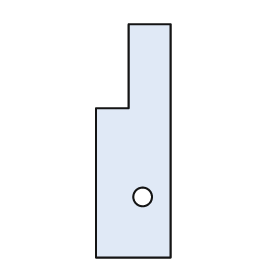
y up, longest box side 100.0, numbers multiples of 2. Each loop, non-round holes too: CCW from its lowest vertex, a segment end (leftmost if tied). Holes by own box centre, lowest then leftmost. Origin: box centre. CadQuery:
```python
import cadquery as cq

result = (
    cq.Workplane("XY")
    .moveTo(-16.0, -50.0)
    .lineTo(16.0, -50.0)
    .lineTo(16.0, 50.0)
    .lineTo(-2.0, 50.0)
    .lineTo(-2.0, 14.0)
    .lineTo(-16.0, 14.0)
    .close()
    .moveTo(4.0, -24.0)
    .circle(4.0)
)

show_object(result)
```